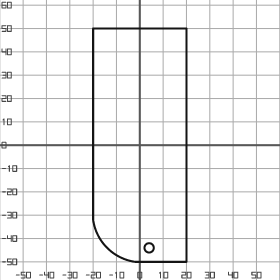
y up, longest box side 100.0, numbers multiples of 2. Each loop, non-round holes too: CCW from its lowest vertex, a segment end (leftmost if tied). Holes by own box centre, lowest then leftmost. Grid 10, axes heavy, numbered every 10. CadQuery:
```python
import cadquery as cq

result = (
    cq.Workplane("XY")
    .moveTo(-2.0, -50.0)
    .lineTo(20.0, -50.0)
    .lineTo(20.0, 50.0)
    .lineTo(-20.0, 50.0)
    .lineTo(-20.0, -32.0)
    .threePointArc((-14.0, -44.0), (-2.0, -50.0))
    .close()
    .moveTo(4.0, -44.0)
    .circle(2.0)
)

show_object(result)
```